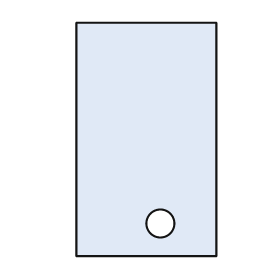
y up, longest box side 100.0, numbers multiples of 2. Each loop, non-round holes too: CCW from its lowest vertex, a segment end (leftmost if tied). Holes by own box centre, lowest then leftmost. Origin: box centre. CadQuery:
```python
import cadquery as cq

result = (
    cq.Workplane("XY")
    .moveTo(-30.0, -50.0)
    .lineTo(30.0, -50.0)
    .lineTo(30.0, 50.0)
    .lineTo(-30.0, 50.0)
    .close()
    .moveTo(6.0, -36.0)
    .circle(6.0)
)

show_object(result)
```